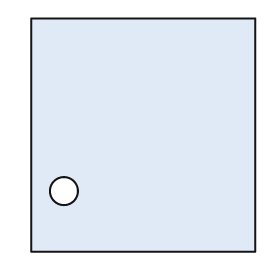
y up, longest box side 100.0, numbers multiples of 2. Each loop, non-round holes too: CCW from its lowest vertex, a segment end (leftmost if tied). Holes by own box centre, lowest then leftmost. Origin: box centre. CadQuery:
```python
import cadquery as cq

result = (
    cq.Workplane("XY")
    .moveTo(-48.0, -50.0)
    .lineTo(48.0, -50.0)
    .lineTo(48.0, 50.0)
    .lineTo(-48.0, 50.0)
    .close()
    .moveTo(-34.0, -24.0)
    .circle(6.0)
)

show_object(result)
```